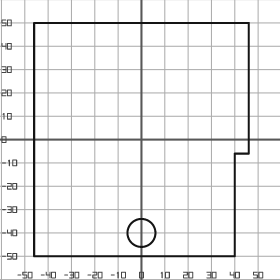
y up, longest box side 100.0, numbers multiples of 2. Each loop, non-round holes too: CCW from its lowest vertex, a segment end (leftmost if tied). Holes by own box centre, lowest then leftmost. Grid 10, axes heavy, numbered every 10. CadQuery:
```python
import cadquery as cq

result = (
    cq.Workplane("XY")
    .moveTo(-46.0, -50.0)
    .lineTo(40.0, -50.0)
    .lineTo(40.0, -6.0)
    .lineTo(46.0, -6.0)
    .lineTo(46.0, 50.0)
    .lineTo(-46.0, 50.0)
    .close()
    .moveTo(0.0, -40.0)
    .circle(6.0)
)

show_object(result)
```